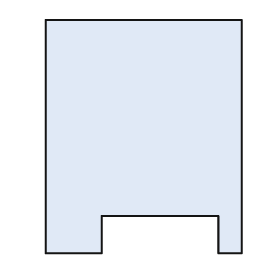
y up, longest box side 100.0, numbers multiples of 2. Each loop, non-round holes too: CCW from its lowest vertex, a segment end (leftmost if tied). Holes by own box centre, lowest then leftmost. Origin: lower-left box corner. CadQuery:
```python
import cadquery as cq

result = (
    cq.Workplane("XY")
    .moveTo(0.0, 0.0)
    .lineTo(24.0, 0.0)
    .lineTo(24.0, 16.0)
    .lineTo(74.0, 16.0)
    .lineTo(74.0, 0.0)
    .lineTo(84.0, 0.0)
    .lineTo(84.0, 100.0)
    .lineTo(0.0, 100.0)
    .close()
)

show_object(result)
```